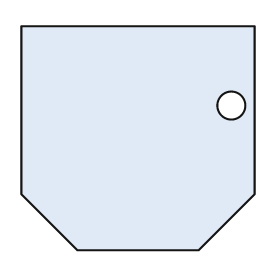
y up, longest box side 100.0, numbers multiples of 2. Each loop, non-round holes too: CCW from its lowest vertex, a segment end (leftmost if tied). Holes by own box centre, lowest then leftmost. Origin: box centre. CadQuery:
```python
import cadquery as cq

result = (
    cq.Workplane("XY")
    .moveTo(-26.0, -48.0)
    .lineTo(26.0, -48.0)
    .lineTo(50.0, -24.0)
    .lineTo(50.0, 48.0)
    .lineTo(-50.0, 48.0)
    .lineTo(-50.0, -24.0)
    .close()
    .moveTo(40.0, 14.0)
    .circle(6.0)
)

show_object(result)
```